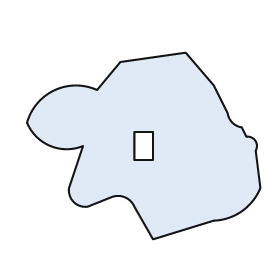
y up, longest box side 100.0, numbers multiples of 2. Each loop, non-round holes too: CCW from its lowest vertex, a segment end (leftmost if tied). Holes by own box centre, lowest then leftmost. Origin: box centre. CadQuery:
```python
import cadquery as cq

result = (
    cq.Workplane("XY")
    .moveTo(4.0, -40.0)
    .lineTo(30.0, -32.0)
    .threePointArc((42.0, -28.0), (50.0, -18.0))
    .lineTo(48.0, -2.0)
    .threePointArc((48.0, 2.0), (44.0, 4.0))
    .lineTo(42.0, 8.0)
    .threePointArc((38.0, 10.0), (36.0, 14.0))
    .lineTo(30.0, 26.0)
    .lineTo(18.0, 40.0)
    .lineTo(-10.0, 36.0)
    .lineTo(-20.0, 24.0)
    .threePointArc((-38.0, 24.0), (-50.0, 10.0))
    .threePointArc((-40.0, 0.0), (-26.0, 0.0))
    .lineTo(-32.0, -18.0)
    .threePointArc((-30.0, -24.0), (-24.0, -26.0))
    .lineTo(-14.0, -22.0)
    .threePointArc((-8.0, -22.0), (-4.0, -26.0))
    .close()
    .moveTo(-4.0, -6.0)
    .lineTo(4.0, -6.0)
    .lineTo(4.0, 6.0)
    .lineTo(-4.0, 6.0)
    .close()
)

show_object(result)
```